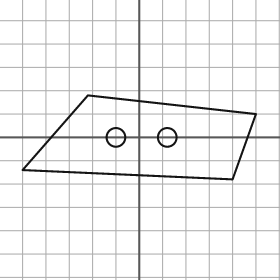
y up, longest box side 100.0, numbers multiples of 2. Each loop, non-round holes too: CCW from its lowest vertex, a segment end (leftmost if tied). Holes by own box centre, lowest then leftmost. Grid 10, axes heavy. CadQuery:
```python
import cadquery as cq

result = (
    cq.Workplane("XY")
    .moveTo(40.0, -18.0)
    .lineTo(50.0, 10.0)
    .lineTo(-22.0, 18.0)
    .lineTo(-50.0, -14.0)
    .close()
    .moveTo(-10.0, 0.0)
    .circle(4.0)
    .moveTo(12.0, 0.0)
    .circle(4.0)
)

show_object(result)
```